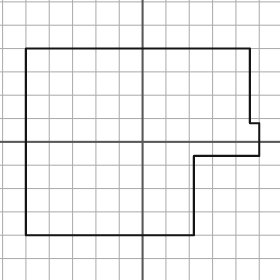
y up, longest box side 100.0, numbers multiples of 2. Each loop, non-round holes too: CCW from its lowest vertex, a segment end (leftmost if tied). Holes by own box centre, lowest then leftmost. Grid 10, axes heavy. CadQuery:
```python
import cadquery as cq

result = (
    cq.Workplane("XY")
    .moveTo(-50.0, -40.0)
    .lineTo(22.0, -40.0)
    .lineTo(22.0, -6.0)
    .lineTo(50.0, -6.0)
    .lineTo(50.0, 8.0)
    .lineTo(46.0, 8.0)
    .lineTo(46.0, 40.0)
    .lineTo(-50.0, 40.0)
    .close()
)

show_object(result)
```